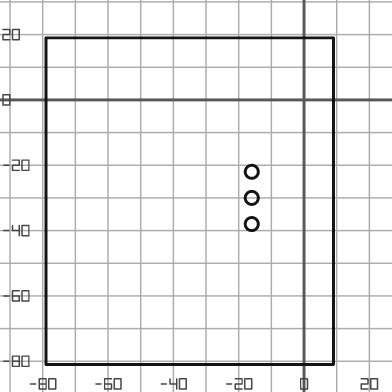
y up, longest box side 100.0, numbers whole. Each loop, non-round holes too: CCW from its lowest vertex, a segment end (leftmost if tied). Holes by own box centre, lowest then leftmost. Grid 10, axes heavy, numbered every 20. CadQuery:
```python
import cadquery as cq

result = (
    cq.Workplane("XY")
    .moveTo(-79.0, -81.0)
    .lineTo(9.0, -81.0)
    .lineTo(9.0, 19.0)
    .lineTo(-79.0, 19.0)
    .close()
    .moveTo(-16.0, -38.0)
    .circle(2.0)
    .moveTo(-16.0, -30.0)
    .circle(2.0)
    .moveTo(-16.0, -22.0)
    .circle(2.0)
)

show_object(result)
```